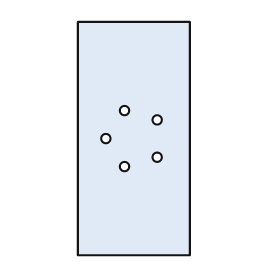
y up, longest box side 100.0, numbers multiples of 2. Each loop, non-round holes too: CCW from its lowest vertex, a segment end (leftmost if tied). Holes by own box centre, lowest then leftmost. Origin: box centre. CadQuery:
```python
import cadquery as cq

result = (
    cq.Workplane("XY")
    .moveTo(-24.0, -50.0)
    .lineTo(24.0, -50.0)
    .lineTo(24.0, 50.0)
    .lineTo(-24.0, 50.0)
    .close()
    .moveTo(-4.0, -12.0)
    .circle(2.0)
    .moveTo(10.0, -8.0)
    .circle(2.0)
    .moveTo(-12.0, 0.0)
    .circle(2.0)
    .moveTo(10.0, 8.0)
    .circle(2.0)
    .moveTo(-4.0, 12.0)
    .circle(2.0)
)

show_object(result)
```